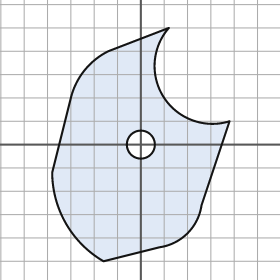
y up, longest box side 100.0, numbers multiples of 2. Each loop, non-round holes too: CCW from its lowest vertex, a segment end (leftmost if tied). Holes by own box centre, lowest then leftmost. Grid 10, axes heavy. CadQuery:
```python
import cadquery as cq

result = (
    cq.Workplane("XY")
    .moveTo(-16.0, -50.0)
    .lineTo(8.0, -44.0)
    .threePointArc((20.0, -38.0), (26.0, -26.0))
    .lineTo(38.0, 10.0)
    .threePointArc((10.0, 20.0), (12.0, 50.0))
    .lineTo(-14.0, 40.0)
    .threePointArc((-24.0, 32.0), (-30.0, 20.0))
    .lineTo(-38.0, -12.0)
    .threePointArc((-32.0, -34.0), (-16.0, -50.0))
    .close()
    .moveTo(0.0, 0.0)
    .circle(6.0)
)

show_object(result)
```